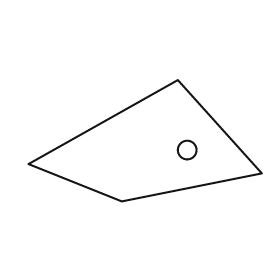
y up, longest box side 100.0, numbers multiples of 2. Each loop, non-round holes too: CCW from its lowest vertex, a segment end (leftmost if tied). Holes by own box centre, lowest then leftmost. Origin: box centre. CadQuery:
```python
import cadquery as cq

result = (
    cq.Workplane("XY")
    .moveTo(-10.0, -26.0)
    .lineTo(50.0, -14.0)
    .lineTo(14.0, 26.0)
    .lineTo(-50.0, -10.0)
    .close()
    .moveTo(18.0, -4.0)
    .circle(4.0)
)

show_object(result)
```